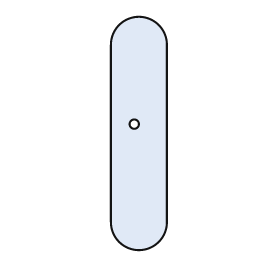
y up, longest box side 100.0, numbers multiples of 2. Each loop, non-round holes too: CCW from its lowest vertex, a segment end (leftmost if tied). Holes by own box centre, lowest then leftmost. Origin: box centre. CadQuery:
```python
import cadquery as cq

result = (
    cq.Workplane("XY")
    .moveTo(-12.0, -38.0)
    .threePointArc((0.0, -50.0), (12.0, -38.0))
    .lineTo(12.0, 38.0)
    .threePointArc((0.0, 50.0), (-12.0, 38.0))
    .close()
    .moveTo(-2.0, 4.0)
    .circle(2.0)
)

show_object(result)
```